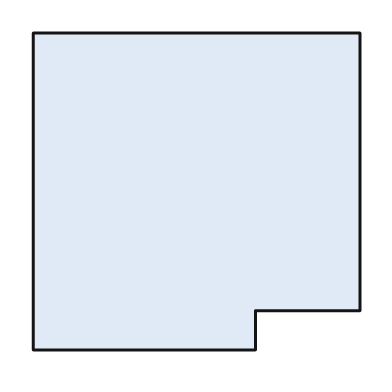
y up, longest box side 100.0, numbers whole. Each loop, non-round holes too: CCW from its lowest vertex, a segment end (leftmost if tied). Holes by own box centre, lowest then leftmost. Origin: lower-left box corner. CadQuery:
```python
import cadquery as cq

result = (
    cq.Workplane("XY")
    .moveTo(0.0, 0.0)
    .lineTo(68.0, 0.0)
    .lineTo(68.0, 12.0)
    .lineTo(100.0, 12.0)
    .lineTo(100.0, 97.0)
    .lineTo(0.0, 97.0)
    .close()
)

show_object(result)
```